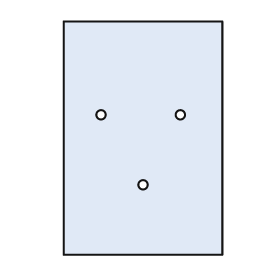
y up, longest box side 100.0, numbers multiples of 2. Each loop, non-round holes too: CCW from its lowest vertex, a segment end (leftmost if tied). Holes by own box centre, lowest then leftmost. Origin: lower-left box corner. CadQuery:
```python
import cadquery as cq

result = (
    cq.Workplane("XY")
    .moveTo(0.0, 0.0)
    .lineTo(68.0, 0.0)
    .lineTo(68.0, 100.0)
    .lineTo(0.0, 100.0)
    .close()
    .moveTo(34.0, 30.0)
    .circle(2.0)
    .moveTo(16.0, 60.0)
    .circle(2.0)
    .moveTo(50.0, 60.0)
    .circle(2.0)
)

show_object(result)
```